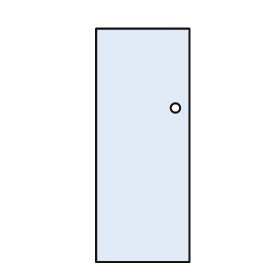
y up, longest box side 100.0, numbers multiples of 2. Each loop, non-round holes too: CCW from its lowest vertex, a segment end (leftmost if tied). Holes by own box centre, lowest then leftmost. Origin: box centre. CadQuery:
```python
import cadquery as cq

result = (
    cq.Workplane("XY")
    .moveTo(-20.0, -50.0)
    .lineTo(20.0, -50.0)
    .lineTo(20.0, 50.0)
    .lineTo(-20.0, 50.0)
    .close()
    .moveTo(14.0, 16.0)
    .circle(2.0)
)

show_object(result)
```